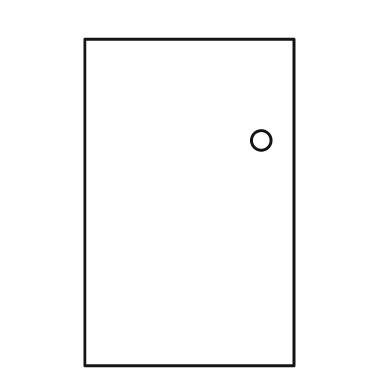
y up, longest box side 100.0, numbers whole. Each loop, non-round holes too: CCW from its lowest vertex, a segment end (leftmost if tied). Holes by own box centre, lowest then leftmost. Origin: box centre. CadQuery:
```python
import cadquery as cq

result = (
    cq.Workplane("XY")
    .moveTo(-32.0, -50.0)
    .lineTo(32.0, -50.0)
    .lineTo(32.0, 50.0)
    .lineTo(-32.0, 50.0)
    .close()
    .moveTo(22.0, 19.0)
    .circle(3.0)
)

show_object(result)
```